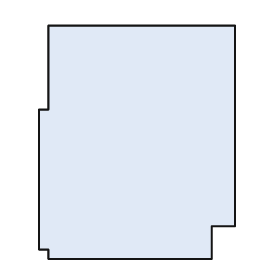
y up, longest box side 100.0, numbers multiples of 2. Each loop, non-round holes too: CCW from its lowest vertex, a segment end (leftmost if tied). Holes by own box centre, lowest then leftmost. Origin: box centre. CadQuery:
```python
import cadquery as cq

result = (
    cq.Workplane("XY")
    .moveTo(-38.0, -50.0)
    .lineTo(32.0, -50.0)
    .lineTo(32.0, -36.0)
    .lineTo(42.0, -36.0)
    .lineTo(42.0, 50.0)
    .lineTo(-38.0, 50.0)
    .lineTo(-38.0, 14.0)
    .lineTo(-42.0, 14.0)
    .lineTo(-42.0, -46.0)
    .lineTo(-38.0, -46.0)
    .close()
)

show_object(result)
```